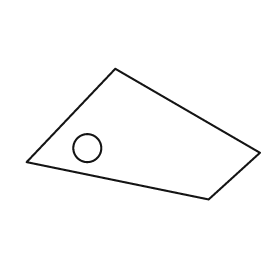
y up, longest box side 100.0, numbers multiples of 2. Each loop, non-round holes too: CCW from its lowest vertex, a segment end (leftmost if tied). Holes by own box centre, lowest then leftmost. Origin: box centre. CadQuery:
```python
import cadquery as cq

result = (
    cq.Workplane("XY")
    .moveTo(28.0, -28.0)
    .lineTo(50.0, -8.0)
    .lineTo(-12.0, 28.0)
    .lineTo(-50.0, -12.0)
    .close()
    .moveTo(-24.0, -6.0)
    .circle(6.0)
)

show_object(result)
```